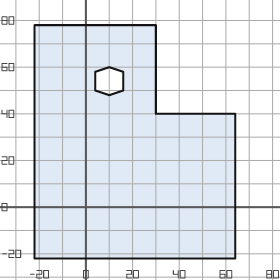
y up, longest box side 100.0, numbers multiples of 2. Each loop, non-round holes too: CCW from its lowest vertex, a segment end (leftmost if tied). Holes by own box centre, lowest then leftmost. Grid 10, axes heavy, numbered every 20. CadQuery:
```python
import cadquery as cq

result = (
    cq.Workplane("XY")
    .moveTo(-22.0, -22.0)
    .lineTo(64.0, -22.0)
    .lineTo(64.0, 40.0)
    .lineTo(30.0, 40.0)
    .lineTo(30.0, 78.0)
    .lineTo(-22.0, 78.0)
    .close()
    .moveTo(10.0, 48.0)
    .lineTo(16.0, 50.0)
    .lineTo(16.0, 58.0)
    .lineTo(10.0, 60.0)
    .lineTo(4.0, 58.0)
    .lineTo(4.0, 50.0)
    .close()
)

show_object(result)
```